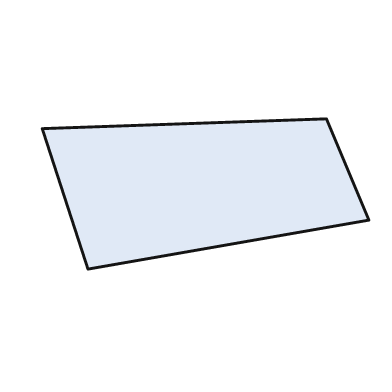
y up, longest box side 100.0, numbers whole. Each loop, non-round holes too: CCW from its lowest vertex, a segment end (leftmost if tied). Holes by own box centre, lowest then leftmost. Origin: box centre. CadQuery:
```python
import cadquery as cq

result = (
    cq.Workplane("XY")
    .moveTo(-36.0, -23.0)
    .lineTo(50.0, -8.0)
    .lineTo(37.0, 23.0)
    .lineTo(-50.0, 20.0)
    .close()
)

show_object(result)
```